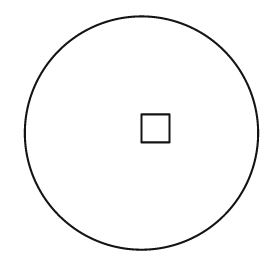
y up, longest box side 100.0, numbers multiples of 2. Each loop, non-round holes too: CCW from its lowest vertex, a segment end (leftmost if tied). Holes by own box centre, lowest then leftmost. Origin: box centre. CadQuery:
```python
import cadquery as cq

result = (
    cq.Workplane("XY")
    .moveTo(0.0, 0.0)
    .circle(50.0)
    .moveTo(0.0, -4.0)
    .lineTo(12.0, -4.0)
    .lineTo(12.0, 8.0)
    .lineTo(0.0, 8.0)
    .close()
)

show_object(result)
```